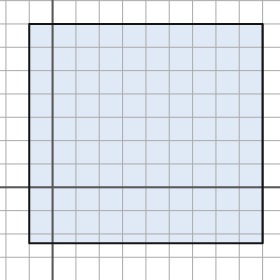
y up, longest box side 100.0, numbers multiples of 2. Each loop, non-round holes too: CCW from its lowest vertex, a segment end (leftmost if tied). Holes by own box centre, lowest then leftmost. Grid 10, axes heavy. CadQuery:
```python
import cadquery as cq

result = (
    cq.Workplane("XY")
    .moveTo(-10.0, -24.0)
    .lineTo(90.0, -24.0)
    .lineTo(90.0, 70.0)
    .lineTo(-10.0, 70.0)
    .close()
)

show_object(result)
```